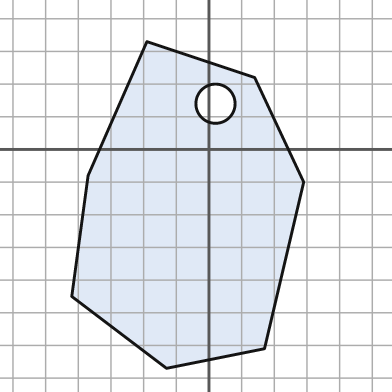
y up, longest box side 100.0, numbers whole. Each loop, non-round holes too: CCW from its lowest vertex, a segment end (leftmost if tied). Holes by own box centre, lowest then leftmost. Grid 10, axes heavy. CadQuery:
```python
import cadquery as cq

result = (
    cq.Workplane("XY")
    .moveTo(-13.0, -67.0)
    .lineTo(17.0, -61.0)
    .lineTo(29.0, -10.0)
    .lineTo(14.0, 22.0)
    .lineTo(-19.0, 33.0)
    .lineTo(-37.0, -8.0)
    .lineTo(-42.0, -45.0)
    .close()
    .moveTo(2.0, 14.0)
    .circle(6.0)
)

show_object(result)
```